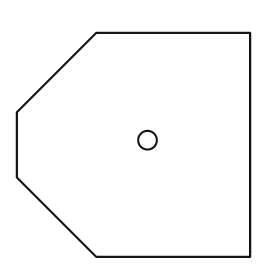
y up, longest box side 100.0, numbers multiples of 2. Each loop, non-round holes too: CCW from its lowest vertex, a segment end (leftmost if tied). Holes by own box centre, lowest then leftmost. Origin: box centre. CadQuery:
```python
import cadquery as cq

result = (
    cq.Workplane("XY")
    .moveTo(-16.0, -48.0)
    .lineTo(50.0, -48.0)
    .lineTo(50.0, 48.0)
    .lineTo(-16.0, 48.0)
    .lineTo(-50.0, 14.0)
    .lineTo(-50.0, -14.0)
    .close()
    .moveTo(6.0, 2.0)
    .circle(4.0)
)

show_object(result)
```